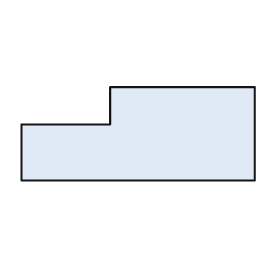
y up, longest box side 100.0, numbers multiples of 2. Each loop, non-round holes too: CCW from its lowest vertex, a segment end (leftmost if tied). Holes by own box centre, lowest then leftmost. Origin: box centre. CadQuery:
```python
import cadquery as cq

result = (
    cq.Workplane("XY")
    .moveTo(-50.0, -20.0)
    .lineTo(50.0, -20.0)
    .lineTo(50.0, 20.0)
    .lineTo(-12.0, 20.0)
    .lineTo(-12.0, 4.0)
    .lineTo(-50.0, 4.0)
    .close()
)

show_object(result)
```